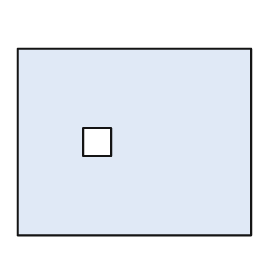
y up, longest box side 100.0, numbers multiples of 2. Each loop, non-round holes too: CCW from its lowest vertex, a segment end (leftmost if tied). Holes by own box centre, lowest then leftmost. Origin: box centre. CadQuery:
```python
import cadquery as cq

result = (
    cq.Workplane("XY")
    .moveTo(-50.0, -40.0)
    .lineTo(50.0, -40.0)
    .lineTo(50.0, 40.0)
    .lineTo(-50.0, 40.0)
    .close()
    .moveTo(-22.0, -6.0)
    .lineTo(-10.0, -6.0)
    .lineTo(-10.0, 6.0)
    .lineTo(-22.0, 6.0)
    .close()
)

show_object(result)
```